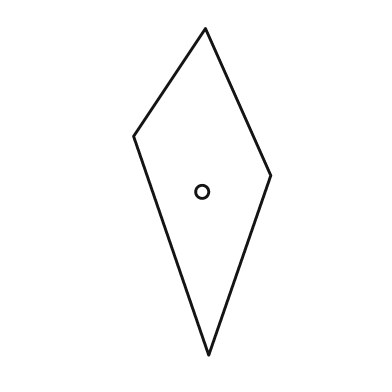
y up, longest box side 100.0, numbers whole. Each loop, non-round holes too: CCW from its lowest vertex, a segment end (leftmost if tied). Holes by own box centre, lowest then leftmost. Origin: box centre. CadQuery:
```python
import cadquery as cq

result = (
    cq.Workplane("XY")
    .moveTo(2.0, -50.0)
    .lineTo(21.0, 5.0)
    .lineTo(1.0, 50.0)
    .lineTo(-21.0, 17.0)
    .close()
    .moveTo(0.0, 0.0)
    .circle(2.0)
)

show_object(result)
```